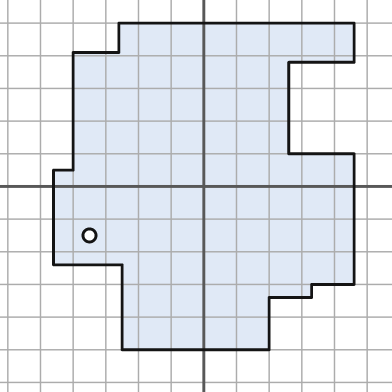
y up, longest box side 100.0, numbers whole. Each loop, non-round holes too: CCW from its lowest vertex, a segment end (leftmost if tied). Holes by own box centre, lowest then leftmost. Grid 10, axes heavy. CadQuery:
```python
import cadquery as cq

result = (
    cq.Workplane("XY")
    .moveTo(-25.0, -50.0)
    .lineTo(20.0, -50.0)
    .lineTo(20.0, -34.0)
    .lineTo(33.0, -34.0)
    .lineTo(33.0, -30.0)
    .lineTo(46.0, -30.0)
    .lineTo(46.0, 10.0)
    .lineTo(26.0, 10.0)
    .lineTo(26.0, 38.0)
    .lineTo(46.0, 38.0)
    .lineTo(46.0, 50.0)
    .lineTo(-26.0, 50.0)
    .lineTo(-26.0, 41.0)
    .lineTo(-40.0, 41.0)
    .lineTo(-40.0, 5.0)
    .lineTo(-46.0, 5.0)
    .lineTo(-46.0, -24.0)
    .lineTo(-25.0, -24.0)
    .close()
    .moveTo(-35.0, -15.0)
    .circle(2.0)
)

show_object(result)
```